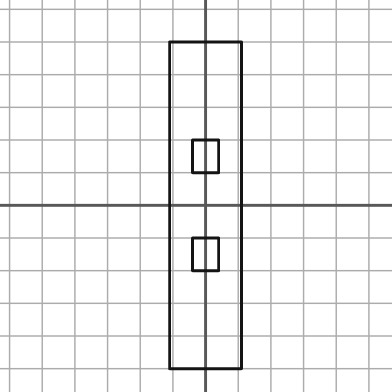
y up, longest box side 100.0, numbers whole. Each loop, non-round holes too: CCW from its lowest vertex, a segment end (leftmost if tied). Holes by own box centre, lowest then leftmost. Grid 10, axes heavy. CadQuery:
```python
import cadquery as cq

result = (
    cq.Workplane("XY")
    .moveTo(-11.0, -50.0)
    .lineTo(11.0, -50.0)
    .lineTo(11.0, 50.0)
    .lineTo(-11.0, 50.0)
    .close()
    .moveTo(-4.0, -20.0)
    .lineTo(4.0, -20.0)
    .lineTo(4.0, -10.0)
    .lineTo(-4.0, -10.0)
    .close()
    .moveTo(-4.0, 10.0)
    .lineTo(4.0, 10.0)
    .lineTo(4.0, 20.0)
    .lineTo(-4.0, 20.0)
    .close()
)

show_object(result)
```